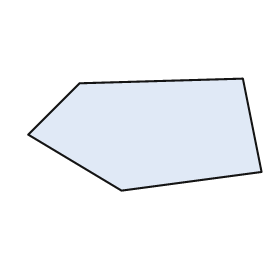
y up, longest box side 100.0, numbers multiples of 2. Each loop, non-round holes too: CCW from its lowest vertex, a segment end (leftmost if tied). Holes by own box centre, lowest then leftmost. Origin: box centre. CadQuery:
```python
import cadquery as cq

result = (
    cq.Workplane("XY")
    .moveTo(-10.0, -24.0)
    .lineTo(50.0, -16.0)
    .lineTo(42.0, 24.0)
    .lineTo(-28.0, 22.0)
    .lineTo(-50.0, 0.0)
    .close()
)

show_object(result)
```